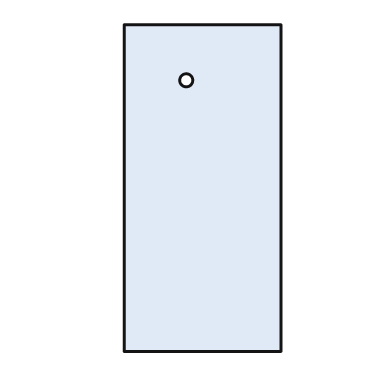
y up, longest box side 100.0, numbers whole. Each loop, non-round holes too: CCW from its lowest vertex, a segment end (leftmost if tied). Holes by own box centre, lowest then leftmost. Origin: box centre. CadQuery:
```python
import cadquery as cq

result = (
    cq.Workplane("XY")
    .moveTo(-24.0, -50.0)
    .lineTo(24.0, -50.0)
    .lineTo(24.0, 50.0)
    .lineTo(-24.0, 50.0)
    .close()
    .moveTo(-5.0, 33.0)
    .circle(2.0)
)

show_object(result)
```